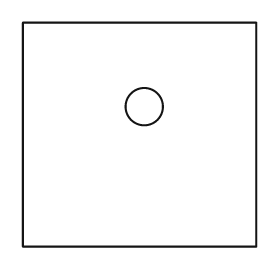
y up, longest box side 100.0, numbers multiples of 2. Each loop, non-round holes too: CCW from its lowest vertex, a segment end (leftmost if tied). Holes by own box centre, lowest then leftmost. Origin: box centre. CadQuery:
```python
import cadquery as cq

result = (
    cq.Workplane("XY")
    .moveTo(-50.0, -48.0)
    .lineTo(50.0, -48.0)
    .lineTo(50.0, 48.0)
    .lineTo(-50.0, 48.0)
    .close()
    .moveTo(2.0, 12.0)
    .circle(8.0)
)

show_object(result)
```